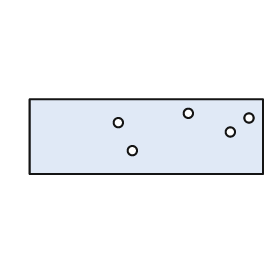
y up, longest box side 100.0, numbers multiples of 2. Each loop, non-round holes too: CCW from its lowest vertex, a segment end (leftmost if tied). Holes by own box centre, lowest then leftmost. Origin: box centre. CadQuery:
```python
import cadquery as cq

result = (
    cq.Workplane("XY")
    .moveTo(-50.0, -16.0)
    .lineTo(50.0, -16.0)
    .lineTo(50.0, 16.0)
    .lineTo(-50.0, 16.0)
    .close()
    .moveTo(-6.0, -6.0)
    .circle(2.0)
    .moveTo(36.0, 2.0)
    .circle(2.0)
    .moveTo(-12.0, 6.0)
    .circle(2.0)
    .moveTo(44.0, 8.0)
    .circle(2.0)
    .moveTo(18.0, 10.0)
    .circle(2.0)
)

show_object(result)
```